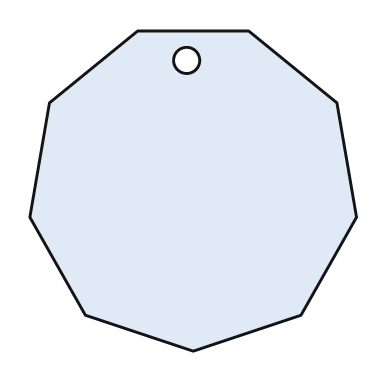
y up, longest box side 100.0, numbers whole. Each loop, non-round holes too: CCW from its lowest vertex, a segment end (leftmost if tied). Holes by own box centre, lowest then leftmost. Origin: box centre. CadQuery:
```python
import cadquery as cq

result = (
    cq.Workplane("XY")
    .moveTo(0.0, -49.0)
    .lineTo(33.0, -38.0)
    .lineTo(50.0, -8.0)
    .lineTo(44.0, 27.0)
    .lineTo(17.0, 49.0)
    .lineTo(-17.0, 49.0)
    .lineTo(-44.0, 27.0)
    .lineTo(-50.0, -8.0)
    .lineTo(-33.0, -38.0)
    .close()
    .moveTo(-2.0, 40.0)
    .circle(4.0)
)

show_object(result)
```